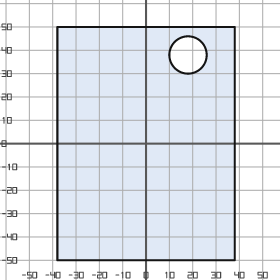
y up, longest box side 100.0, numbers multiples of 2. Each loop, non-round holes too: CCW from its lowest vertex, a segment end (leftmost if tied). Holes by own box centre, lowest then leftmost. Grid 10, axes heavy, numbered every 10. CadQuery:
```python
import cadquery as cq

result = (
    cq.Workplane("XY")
    .moveTo(-38.0, -50.0)
    .lineTo(38.0, -50.0)
    .lineTo(38.0, 50.0)
    .lineTo(-38.0, 50.0)
    .close()
    .moveTo(18.0, 38.0)
    .circle(8.0)
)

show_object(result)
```